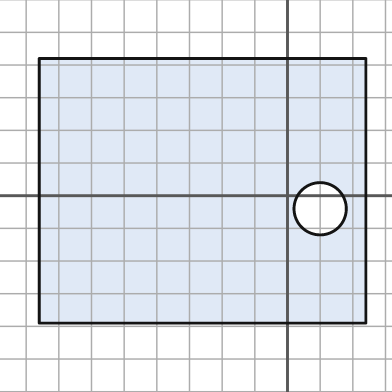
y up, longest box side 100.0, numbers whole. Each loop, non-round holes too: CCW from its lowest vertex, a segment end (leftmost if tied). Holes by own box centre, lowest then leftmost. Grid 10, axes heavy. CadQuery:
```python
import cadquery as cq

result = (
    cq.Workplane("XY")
    .moveTo(-76.0, -39.0)
    .lineTo(24.0, -39.0)
    .lineTo(24.0, 42.0)
    .lineTo(-76.0, 42.0)
    .close()
    .moveTo(10.0, -4.0)
    .circle(8.0)
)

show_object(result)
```